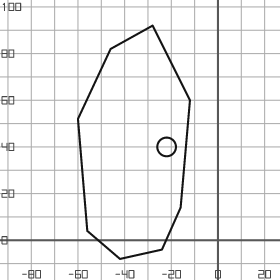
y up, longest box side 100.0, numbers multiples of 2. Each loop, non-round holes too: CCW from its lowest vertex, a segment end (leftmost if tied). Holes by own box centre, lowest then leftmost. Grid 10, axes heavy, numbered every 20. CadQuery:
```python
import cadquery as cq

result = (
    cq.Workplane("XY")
    .moveTo(-42.0, -8.0)
    .lineTo(-24.0, -4.0)
    .lineTo(-16.0, 14.0)
    .lineTo(-12.0, 60.0)
    .lineTo(-28.0, 92.0)
    .lineTo(-46.0, 82.0)
    .lineTo(-60.0, 52.0)
    .lineTo(-56.0, 4.0)
    .close()
    .moveTo(-22.0, 40.0)
    .circle(4.0)
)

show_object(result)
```